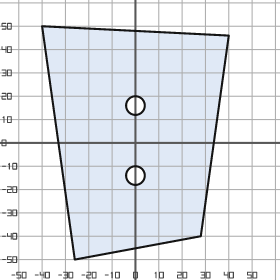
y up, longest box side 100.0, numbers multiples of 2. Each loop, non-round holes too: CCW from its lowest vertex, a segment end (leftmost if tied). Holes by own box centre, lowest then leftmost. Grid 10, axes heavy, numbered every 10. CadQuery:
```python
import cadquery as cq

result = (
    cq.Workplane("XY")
    .moveTo(-26.0, -50.0)
    .lineTo(28.0, -40.0)
    .lineTo(40.0, 46.0)
    .lineTo(-40.0, 50.0)
    .close()
    .moveTo(0.0, -14.0)
    .circle(4.0)
    .moveTo(0.0, 16.0)
    .circle(4.0)
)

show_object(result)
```